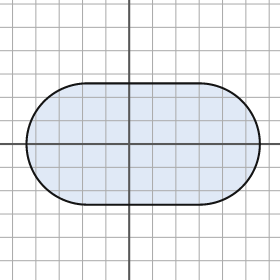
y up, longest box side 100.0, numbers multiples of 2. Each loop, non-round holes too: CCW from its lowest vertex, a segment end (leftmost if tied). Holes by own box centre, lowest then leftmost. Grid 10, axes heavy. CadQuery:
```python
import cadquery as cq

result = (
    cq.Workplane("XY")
    .moveTo(-18.0, -26.0)
    .lineTo(30.0, -26.0)
    .threePointArc((56.0, 0.0), (30.0, 26.0))
    .lineTo(-18.0, 26.0)
    .threePointArc((-44.0, 0.0), (-18.0, -26.0))
    .close()
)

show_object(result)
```